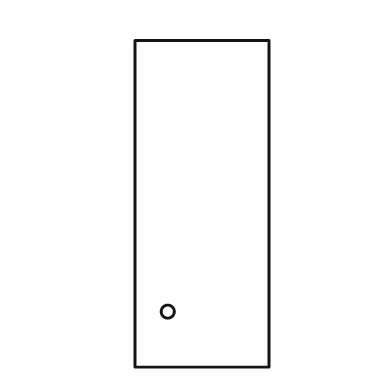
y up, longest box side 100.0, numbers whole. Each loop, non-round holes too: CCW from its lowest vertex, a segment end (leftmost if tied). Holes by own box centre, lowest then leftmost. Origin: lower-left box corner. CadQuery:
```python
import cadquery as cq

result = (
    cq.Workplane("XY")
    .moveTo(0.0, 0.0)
    .lineTo(41.0, 0.0)
    .lineTo(41.0, 100.0)
    .lineTo(0.0, 100.0)
    .close()
    .moveTo(10.0, 17.0)
    .circle(2.0)
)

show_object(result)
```